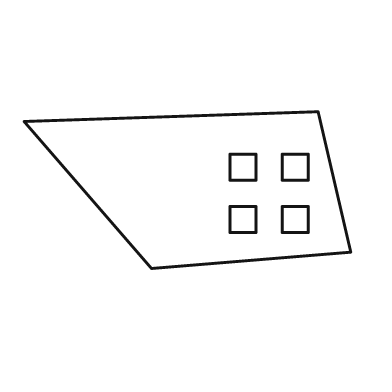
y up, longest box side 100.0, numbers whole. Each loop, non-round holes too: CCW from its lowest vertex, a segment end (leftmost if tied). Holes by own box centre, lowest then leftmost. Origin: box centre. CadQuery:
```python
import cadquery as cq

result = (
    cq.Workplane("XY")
    .moveTo(-11.0, -24.0)
    .lineTo(50.0, -19.0)
    .lineTo(40.0, 24.0)
    .lineTo(-50.0, 21.0)
    .close()
    .moveTo(13.0, -13.0)
    .lineTo(21.0, -13.0)
    .lineTo(21.0, -5.0)
    .lineTo(13.0, -5.0)
    .close()
    .moveTo(29.0, -13.0)
    .lineTo(37.0, -13.0)
    .lineTo(37.0, -5.0)
    .lineTo(29.0, -5.0)
    .close()
    .moveTo(13.0, 3.0)
    .lineTo(21.0, 3.0)
    .lineTo(21.0, 11.0)
    .lineTo(13.0, 11.0)
    .close()
    .moveTo(29.0, 3.0)
    .lineTo(37.0, 3.0)
    .lineTo(37.0, 11.0)
    .lineTo(29.0, 11.0)
    .close()
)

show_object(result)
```